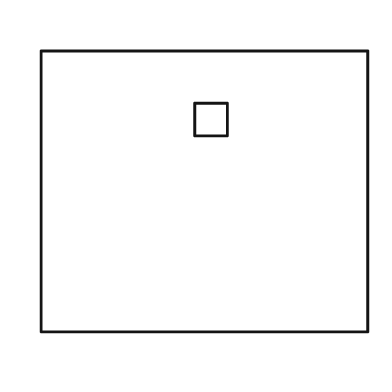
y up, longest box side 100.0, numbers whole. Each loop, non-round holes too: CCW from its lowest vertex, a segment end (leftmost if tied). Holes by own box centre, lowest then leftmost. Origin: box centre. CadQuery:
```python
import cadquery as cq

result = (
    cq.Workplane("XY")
    .moveTo(-50.0, -43.0)
    .lineTo(50.0, -43.0)
    .lineTo(50.0, 43.0)
    .lineTo(-50.0, 43.0)
    .close()
    .moveTo(-3.0, 17.0)
    .lineTo(7.0, 17.0)
    .lineTo(7.0, 27.0)
    .lineTo(-3.0, 27.0)
    .close()
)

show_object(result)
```